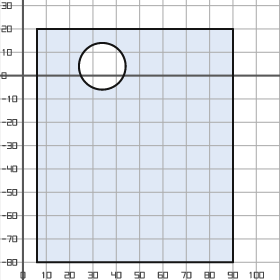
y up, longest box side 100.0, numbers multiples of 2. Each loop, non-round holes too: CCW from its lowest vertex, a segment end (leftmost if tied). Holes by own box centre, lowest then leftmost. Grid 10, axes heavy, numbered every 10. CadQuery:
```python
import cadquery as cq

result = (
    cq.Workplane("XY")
    .moveTo(6.0, -80.0)
    .lineTo(90.0, -80.0)
    .lineTo(90.0, 20.0)
    .lineTo(6.0, 20.0)
    .close()
    .moveTo(34.0, 4.0)
    .circle(10.0)
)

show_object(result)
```